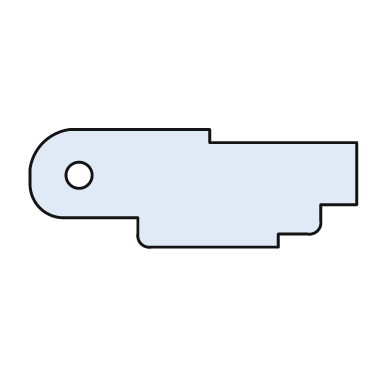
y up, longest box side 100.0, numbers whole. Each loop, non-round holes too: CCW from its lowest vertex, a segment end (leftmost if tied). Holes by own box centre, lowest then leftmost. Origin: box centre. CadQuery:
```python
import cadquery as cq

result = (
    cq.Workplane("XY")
    .moveTo(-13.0, -18.0)
    .lineTo(26.0, -18.0)
    .lineTo(26.0, -14.0)
    .lineTo(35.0, -14.0)
    .threePointArc((38.0, -13.0), (39.0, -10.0))
    .lineTo(39.0, -5.0)
    .lineTo(50.0, -5.0)
    .lineTo(50.0, 14.0)
    .lineTo(5.0, 14.0)
    .lineTo(5.0, 18.0)
    .lineTo(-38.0, 18.0)
    .threePointArc((-46.0, 14.0), (-50.0, 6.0))
    .lineTo(-50.0, 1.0)
    .threePointArc((-47.0, -6.0), (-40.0, -9.0))
    .lineTo(-17.0, -9.0)
    .lineTo(-17.0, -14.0)
    .threePointArc((-16.0, -17.0), (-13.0, -18.0))
    .close()
    .moveTo(-35.0, 4.0)
    .circle(4.0)
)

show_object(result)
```